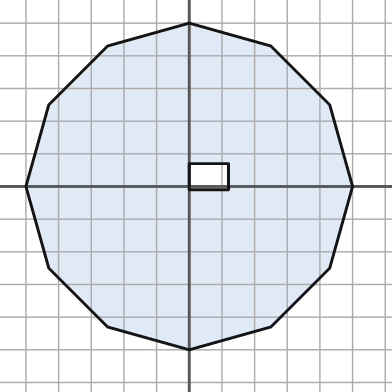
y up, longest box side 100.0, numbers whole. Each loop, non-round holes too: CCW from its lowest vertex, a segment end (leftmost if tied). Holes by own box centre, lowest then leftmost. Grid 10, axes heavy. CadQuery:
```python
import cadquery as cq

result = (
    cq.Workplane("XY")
    .moveTo(0.0, -50.0)
    .lineTo(25.0, -43.0)
    .lineTo(43.0, -25.0)
    .lineTo(50.0, 0.0)
    .lineTo(43.0, 25.0)
    .lineTo(25.0, 43.0)
    .lineTo(0.0, 50.0)
    .lineTo(-25.0, 43.0)
    .lineTo(-43.0, 25.0)
    .lineTo(-50.0, 0.0)
    .lineTo(-43.0, -25.0)
    .lineTo(-25.0, -43.0)
    .close()
    .moveTo(0.0, -1.0)
    .lineTo(12.0, -1.0)
    .lineTo(12.0, 7.0)
    .lineTo(0.0, 7.0)
    .close()
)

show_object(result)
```